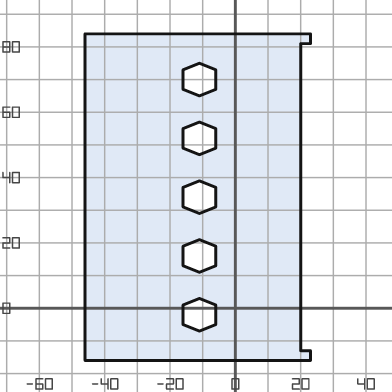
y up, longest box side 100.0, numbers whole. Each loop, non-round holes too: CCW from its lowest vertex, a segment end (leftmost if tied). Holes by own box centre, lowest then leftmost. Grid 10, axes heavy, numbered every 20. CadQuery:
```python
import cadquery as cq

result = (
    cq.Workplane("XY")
    .moveTo(-46.0, -16.0)
    .lineTo(23.0, -16.0)
    .lineTo(23.0, -13.0)
    .lineTo(20.0, -13.0)
    .lineTo(20.0, 81.0)
    .lineTo(23.0, 81.0)
    .lineTo(23.0, 84.0)
    .lineTo(-46.0, 84.0)
    .close()
    .moveTo(-11.0, -7.0)
    .lineTo(-6.0, -5.0)
    .lineTo(-6.0, 1.0)
    .lineTo(-11.0, 3.0)
    .lineTo(-16.0, 1.0)
    .lineTo(-16.0, -5.0)
    .close()
    .moveTo(-11.0, 11.0)
    .lineTo(-6.0, 13.0)
    .lineTo(-6.0, 19.0)
    .lineTo(-11.0, 21.0)
    .lineTo(-16.0, 19.0)
    .lineTo(-16.0, 13.0)
    .close()
    .moveTo(-11.0, 29.0)
    .lineTo(-6.0, 31.0)
    .lineTo(-6.0, 37.0)
    .lineTo(-11.0, 39.0)
    .lineTo(-16.0, 37.0)
    .lineTo(-16.0, 31.0)
    .close()
    .moveTo(-11.0, 47.0)
    .lineTo(-6.0, 49.0)
    .lineTo(-6.0, 55.0)
    .lineTo(-11.0, 57.0)
    .lineTo(-16.0, 55.0)
    .lineTo(-16.0, 49.0)
    .close()
    .moveTo(-11.0, 65.0)
    .lineTo(-6.0, 67.0)
    .lineTo(-6.0, 73.0)
    .lineTo(-11.0, 75.0)
    .lineTo(-16.0, 73.0)
    .lineTo(-16.0, 67.0)
    .close()
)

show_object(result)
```